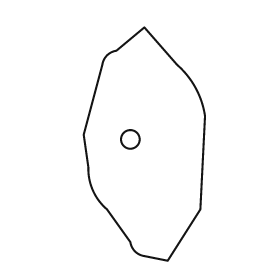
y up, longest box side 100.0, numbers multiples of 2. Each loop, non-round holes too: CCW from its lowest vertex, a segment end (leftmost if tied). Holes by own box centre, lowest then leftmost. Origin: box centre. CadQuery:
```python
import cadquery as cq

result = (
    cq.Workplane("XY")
    .moveTo(10.0, -50.0)
    .lineTo(24.0, -28.0)
    .lineTo(26.0, 12.0)
    .threePointArc((22.0, 24.0), (14.0, 34.0))
    .lineTo(0.0, 50.0)
    .lineTo(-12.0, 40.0)
    .threePointArc((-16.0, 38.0), (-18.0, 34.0))
    .lineTo(-26.0, 4.0)
    .lineTo(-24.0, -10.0)
    .threePointArc((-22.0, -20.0), (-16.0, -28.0))
    .lineTo(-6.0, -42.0)
    .threePointArc((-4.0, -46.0), (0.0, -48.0))
    .close()
    .moveTo(-6.0, 2.0)
    .circle(4.0)
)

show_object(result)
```